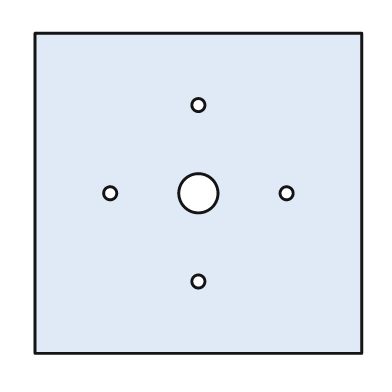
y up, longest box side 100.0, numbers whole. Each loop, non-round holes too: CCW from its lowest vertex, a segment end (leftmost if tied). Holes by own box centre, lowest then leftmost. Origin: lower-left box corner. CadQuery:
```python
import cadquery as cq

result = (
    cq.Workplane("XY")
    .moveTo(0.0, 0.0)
    .lineTo(100.0, 0.0)
    .lineTo(100.0, 98.0)
    .lineTo(0.0, 98.0)
    .close()
    .moveTo(50.0, 22.0)
    .circle(2.0)
    .moveTo(23.0, 49.0)
    .circle(2.0)
    .moveTo(50.0, 49.0)
    .circle(6.0)
    .moveTo(77.0, 49.0)
    .circle(2.0)
    .moveTo(50.0, 76.0)
    .circle(2.0)
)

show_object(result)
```